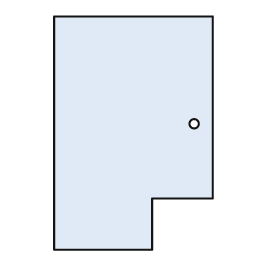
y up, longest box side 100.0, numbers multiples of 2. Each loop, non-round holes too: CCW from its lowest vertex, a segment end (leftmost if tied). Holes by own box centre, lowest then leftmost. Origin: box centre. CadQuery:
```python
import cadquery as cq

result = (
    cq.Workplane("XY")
    .moveTo(-34.0, -50.0)
    .lineTo(8.0, -50.0)
    .lineTo(8.0, -28.0)
    .lineTo(34.0, -28.0)
    .lineTo(34.0, 50.0)
    .lineTo(-34.0, 50.0)
    .close()
    .moveTo(26.0, 4.0)
    .circle(2.0)
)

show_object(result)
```